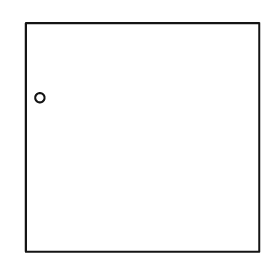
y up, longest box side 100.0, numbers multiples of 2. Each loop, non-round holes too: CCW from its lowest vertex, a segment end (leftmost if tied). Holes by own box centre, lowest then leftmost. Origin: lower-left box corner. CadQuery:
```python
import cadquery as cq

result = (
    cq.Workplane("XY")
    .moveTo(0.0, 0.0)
    .lineTo(100.0, 0.0)
    .lineTo(100.0, 98.0)
    .lineTo(0.0, 98.0)
    .close()
    .moveTo(6.0, 66.0)
    .circle(2.0)
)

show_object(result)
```